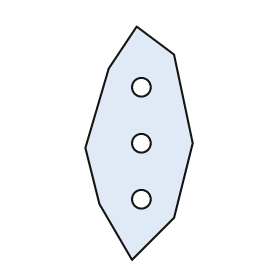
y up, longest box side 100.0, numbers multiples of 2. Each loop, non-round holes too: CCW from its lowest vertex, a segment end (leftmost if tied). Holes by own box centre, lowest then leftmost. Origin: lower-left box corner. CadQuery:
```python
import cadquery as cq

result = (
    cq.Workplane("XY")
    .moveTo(20.0, 0.0)
    .lineTo(38.0, 18.0)
    .lineTo(46.0, 50.0)
    .lineTo(38.0, 88.0)
    .lineTo(22.0, 100.0)
    .lineTo(10.0, 82.0)
    .lineTo(0.0, 48.0)
    .lineTo(6.0, 24.0)
    .close()
    .moveTo(24.0, 26.0)
    .circle(4.0)
    .moveTo(24.0, 50.0)
    .circle(4.0)
    .moveTo(24.0, 74.0)
    .circle(4.0)
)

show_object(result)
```